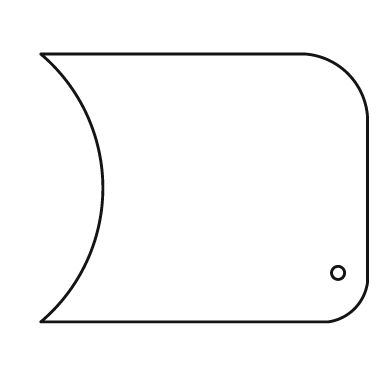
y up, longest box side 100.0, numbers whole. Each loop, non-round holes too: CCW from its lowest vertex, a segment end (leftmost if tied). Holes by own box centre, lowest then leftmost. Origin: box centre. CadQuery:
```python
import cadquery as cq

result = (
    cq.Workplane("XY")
    .moveTo(-50.0, -41.0)
    .lineTo(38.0, -41.0)
    .threePointArc((46.0, -37.0), (50.0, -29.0))
    .lineTo(50.0, 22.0)
    .threePointArc((44.0, 35.0), (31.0, 41.0))
    .lineTo(-50.0, 41.0)
    .threePointArc((-31.0, 0.0), (-50.0, -41.0))
    .close()
    .moveTo(41.0, -26.0)
    .circle(2.0)
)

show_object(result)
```